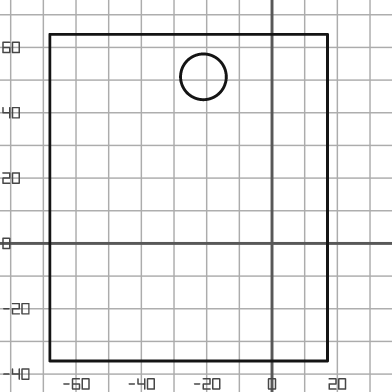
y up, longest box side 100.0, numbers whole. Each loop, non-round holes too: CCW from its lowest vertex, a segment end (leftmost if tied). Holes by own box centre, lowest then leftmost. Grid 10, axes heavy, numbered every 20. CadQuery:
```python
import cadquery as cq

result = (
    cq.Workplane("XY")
    .moveTo(-68.0, -36.0)
    .lineTo(17.0, -36.0)
    .lineTo(17.0, 64.0)
    .lineTo(-68.0, 64.0)
    .close()
    .moveTo(-21.0, 51.0)
    .circle(7.0)
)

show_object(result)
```